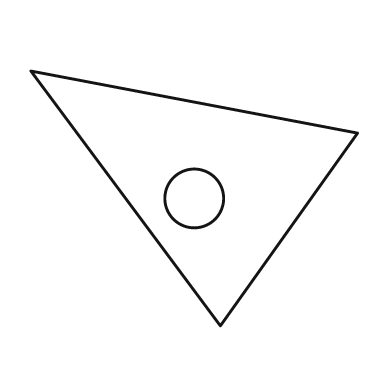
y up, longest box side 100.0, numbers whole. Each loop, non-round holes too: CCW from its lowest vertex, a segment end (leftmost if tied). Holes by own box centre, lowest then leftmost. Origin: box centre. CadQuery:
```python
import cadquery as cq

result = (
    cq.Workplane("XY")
    .moveTo(8.0, -39.0)
    .lineTo(50.0, 20.0)
    .lineTo(-50.0, 39.0)
    .close()
    .moveTo(0.0, 0.0)
    .circle(9.0)
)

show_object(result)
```